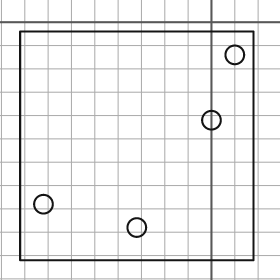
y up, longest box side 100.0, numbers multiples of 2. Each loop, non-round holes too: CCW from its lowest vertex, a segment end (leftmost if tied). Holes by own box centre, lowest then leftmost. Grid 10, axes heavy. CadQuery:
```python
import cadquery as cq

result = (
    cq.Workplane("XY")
    .moveTo(-82.0, -102.0)
    .lineTo(18.0, -102.0)
    .lineTo(18.0, -4.0)
    .lineTo(-82.0, -4.0)
    .close()
    .moveTo(-32.0, -88.0)
    .circle(4.0)
    .moveTo(-72.0, -78.0)
    .circle(4.0)
    .moveTo(0.0, -42.0)
    .circle(4.0)
    .moveTo(10.0, -14.0)
    .circle(4.0)
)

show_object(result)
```